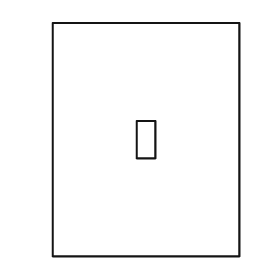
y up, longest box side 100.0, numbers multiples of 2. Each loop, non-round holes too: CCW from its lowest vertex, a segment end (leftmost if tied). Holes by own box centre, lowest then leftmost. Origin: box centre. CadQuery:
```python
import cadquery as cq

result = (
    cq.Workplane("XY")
    .moveTo(-40.0, -50.0)
    .lineTo(40.0, -50.0)
    .lineTo(40.0, 50.0)
    .lineTo(-40.0, 50.0)
    .close()
    .moveTo(-4.0, -8.0)
    .lineTo(4.0, -8.0)
    .lineTo(4.0, 8.0)
    .lineTo(-4.0, 8.0)
    .close()
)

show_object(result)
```